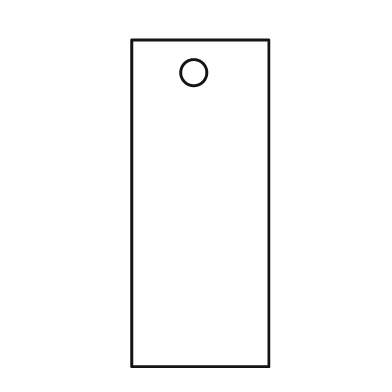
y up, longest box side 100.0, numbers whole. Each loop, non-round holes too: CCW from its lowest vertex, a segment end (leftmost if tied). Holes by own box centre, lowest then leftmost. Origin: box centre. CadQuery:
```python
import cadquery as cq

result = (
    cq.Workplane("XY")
    .moveTo(-21.0, -50.0)
    .lineTo(21.0, -50.0)
    .lineTo(21.0, 50.0)
    .lineTo(-21.0, 50.0)
    .close()
    .moveTo(-2.0, 40.0)
    .circle(4.0)
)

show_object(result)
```